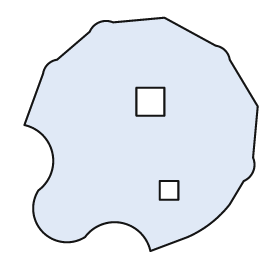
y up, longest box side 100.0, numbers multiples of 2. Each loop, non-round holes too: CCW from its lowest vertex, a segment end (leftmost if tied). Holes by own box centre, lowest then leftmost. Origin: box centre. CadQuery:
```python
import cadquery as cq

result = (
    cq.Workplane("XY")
    .moveTo(4.0, -50.0)
    .lineTo(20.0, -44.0)
    .threePointArc((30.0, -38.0), (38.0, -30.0))
    .lineTo(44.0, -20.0)
    .threePointArc((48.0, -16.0), (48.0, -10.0))
    .lineTo(50.0, 12.0)
    .lineTo(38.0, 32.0)
    .threePointArc((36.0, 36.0), (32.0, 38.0))
    .lineTo(10.0, 50.0)
    .lineTo(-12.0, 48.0)
    .threePointArc((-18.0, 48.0), (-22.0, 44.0))
    .lineTo(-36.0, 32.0)
    .threePointArc((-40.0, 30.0), (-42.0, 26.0))
    .lineTo(-50.0, 4.0)
    .threePointArc((-38.0, -8.0), (-44.0, -24.0))
    .threePointArc((-42.0, -42.0), (-24.0, -44.0))
    .threePointArc((-8.0, -38.0), (4.0, -50.0))
    .close()
    .moveTo(8.0, -28.0)
    .lineTo(16.0, -28.0)
    .lineTo(16.0, -20.0)
    .lineTo(8.0, -20.0)
    .close()
    .moveTo(-2.0, 8.0)
    .lineTo(10.0, 8.0)
    .lineTo(10.0, 20.0)
    .lineTo(-2.0, 20.0)
    .close()
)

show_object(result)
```